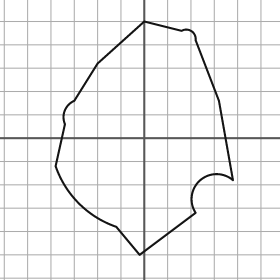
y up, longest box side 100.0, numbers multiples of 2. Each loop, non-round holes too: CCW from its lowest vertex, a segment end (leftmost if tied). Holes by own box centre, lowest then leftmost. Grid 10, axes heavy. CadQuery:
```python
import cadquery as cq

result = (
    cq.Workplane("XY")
    .moveTo(-2.0, -50.0)
    .lineTo(22.0, -32.0)
    .threePointArc((24.0, -18.0), (38.0, -18.0))
    .lineTo(32.0, 16.0)
    .lineTo(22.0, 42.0)
    .threePointArc((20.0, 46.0), (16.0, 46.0))
    .lineTo(0.0, 50.0)
    .lineTo(-20.0, 32.0)
    .lineTo(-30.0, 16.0)
    .threePointArc((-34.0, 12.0), (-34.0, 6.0))
    .lineTo(-38.0, -12.0)
    .threePointArc((-28.0, -28.0), (-12.0, -38.0))
    .close()
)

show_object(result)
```